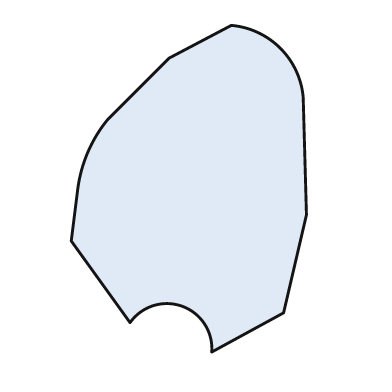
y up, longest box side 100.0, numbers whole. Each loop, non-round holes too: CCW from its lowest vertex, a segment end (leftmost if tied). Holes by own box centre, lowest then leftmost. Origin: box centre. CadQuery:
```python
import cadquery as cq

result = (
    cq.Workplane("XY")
    .moveTo(7.0, -50.0)
    .lineTo(29.0, -38.0)
    .lineTo(36.0, -8.0)
    .lineTo(35.0, 28.0)
    .threePointArc((28.0, 43.0), (13.0, 50.0))
    .lineTo(-6.0, 40.0)
    .lineTo(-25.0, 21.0)
    .threePointArc((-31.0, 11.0), (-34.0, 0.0))
    .lineTo(-36.0, -16.0)
    .lineTo(-18.0, -41.0)
    .threePointArc((-2.0, -36.0), (7.0, -50.0))
    .close()
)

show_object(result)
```